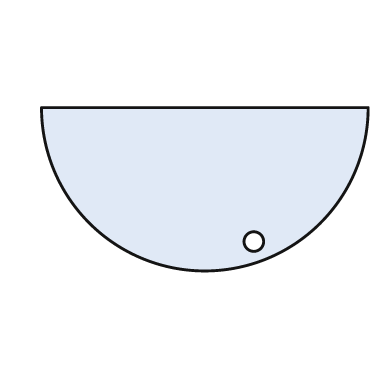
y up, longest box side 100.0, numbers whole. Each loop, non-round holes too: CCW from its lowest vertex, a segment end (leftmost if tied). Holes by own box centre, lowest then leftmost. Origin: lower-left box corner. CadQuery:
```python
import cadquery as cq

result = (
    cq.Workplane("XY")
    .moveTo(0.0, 50.0)
    .threePointArc((50.0, 0.0), (100.0, 50.0))
    .close()
    .moveTo(65.0, 9.0)
    .circle(3.0)
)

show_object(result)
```